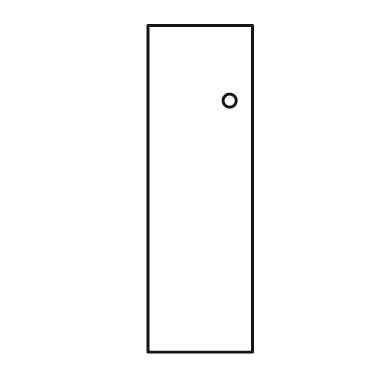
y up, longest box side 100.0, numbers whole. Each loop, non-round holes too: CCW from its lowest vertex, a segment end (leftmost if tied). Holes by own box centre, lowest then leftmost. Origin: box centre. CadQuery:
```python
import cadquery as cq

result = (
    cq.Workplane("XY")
    .moveTo(-16.0, -50.0)
    .lineTo(16.0, -50.0)
    .lineTo(16.0, 50.0)
    .lineTo(-16.0, 50.0)
    .close()
    .moveTo(9.0, 27.0)
    .circle(2.0)
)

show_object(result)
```